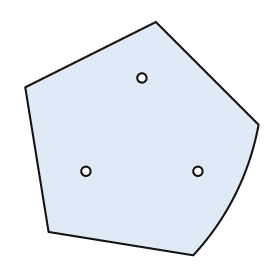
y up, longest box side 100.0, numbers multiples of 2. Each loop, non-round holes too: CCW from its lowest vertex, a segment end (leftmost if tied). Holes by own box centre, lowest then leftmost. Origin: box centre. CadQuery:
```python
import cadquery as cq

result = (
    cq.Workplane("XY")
    .moveTo(22.0, -50.0)
    .threePointArc((40.0, -24.0), (50.0, 6.0))
    .lineTo(6.0, 50.0)
    .lineTo(-50.0, 22.0)
    .lineTo(-40.0, -40.0)
    .close()
    .moveTo(-24.0, -14.0)
    .circle(2.0)
    .moveTo(24.0, -14.0)
    .circle(2.0)
    .moveTo(0.0, 26.0)
    .circle(2.0)
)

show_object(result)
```